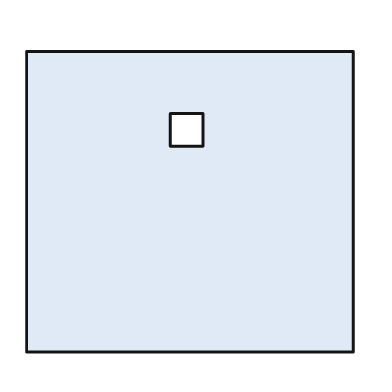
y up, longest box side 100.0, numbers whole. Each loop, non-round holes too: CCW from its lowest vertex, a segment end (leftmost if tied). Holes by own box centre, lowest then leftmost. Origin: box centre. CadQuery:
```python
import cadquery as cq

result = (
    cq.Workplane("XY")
    .moveTo(-50.0, -46.0)
    .lineTo(50.0, -46.0)
    .lineTo(50.0, 46.0)
    .lineTo(-50.0, 46.0)
    .close()
    .moveTo(-6.0, 17.0)
    .lineTo(4.0, 17.0)
    .lineTo(4.0, 27.0)
    .lineTo(-6.0, 27.0)
    .close()
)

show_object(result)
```